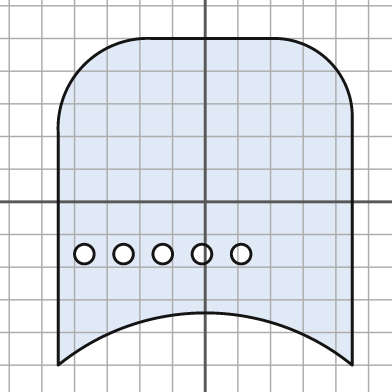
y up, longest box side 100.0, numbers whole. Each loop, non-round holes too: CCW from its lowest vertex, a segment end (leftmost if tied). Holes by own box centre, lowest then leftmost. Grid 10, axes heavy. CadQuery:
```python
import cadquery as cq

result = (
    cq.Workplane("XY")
    .moveTo(-45.0, -50.0)
    .threePointArc((0.0, -34.0), (45.0, -50.0))
    .lineTo(45.0, 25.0)
    .threePointArc((38.0, 43.0), (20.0, 50.0))
    .lineTo(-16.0, 50.0)
    .threePointArc((-37.0, 42.0), (-45.0, 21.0))
    .close()
    .moveTo(-37.0, -16.0)
    .circle(3.0)
    .moveTo(-25.0, -16.0)
    .circle(3.0)
    .moveTo(-13.0, -16.0)
    .circle(3.0)
    .moveTo(-1.0, -16.0)
    .circle(3.0)
    .moveTo(11.0, -16.0)
    .circle(3.0)
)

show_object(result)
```